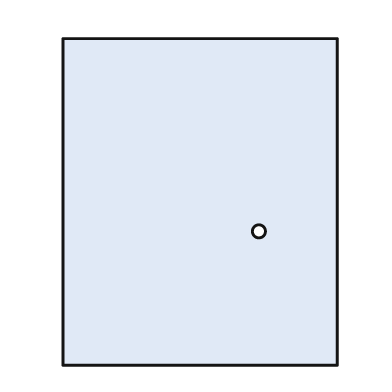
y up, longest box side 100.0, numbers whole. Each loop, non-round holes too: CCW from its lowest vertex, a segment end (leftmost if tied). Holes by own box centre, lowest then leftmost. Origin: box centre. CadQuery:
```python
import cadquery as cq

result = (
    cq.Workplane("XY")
    .moveTo(-42.0, -50.0)
    .lineTo(42.0, -50.0)
    .lineTo(42.0, 50.0)
    .lineTo(-42.0, 50.0)
    .close()
    .moveTo(18.0, -9.0)
    .circle(2.0)
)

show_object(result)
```